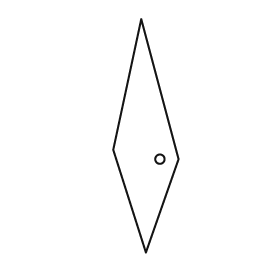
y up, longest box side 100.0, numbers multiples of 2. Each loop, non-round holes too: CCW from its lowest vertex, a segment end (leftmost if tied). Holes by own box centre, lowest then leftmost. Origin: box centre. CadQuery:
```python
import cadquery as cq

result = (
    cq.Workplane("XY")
    .moveTo(0.0, -50.0)
    .lineTo(14.0, -10.0)
    .lineTo(-2.0, 50.0)
    .lineTo(-14.0, -6.0)
    .close()
    .moveTo(6.0, -10.0)
    .circle(2.0)
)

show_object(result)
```